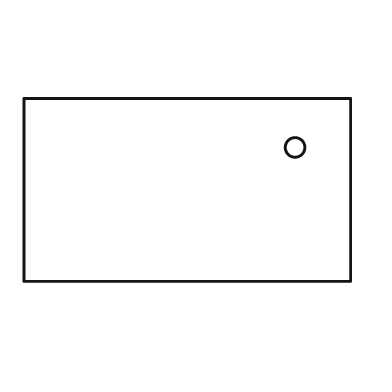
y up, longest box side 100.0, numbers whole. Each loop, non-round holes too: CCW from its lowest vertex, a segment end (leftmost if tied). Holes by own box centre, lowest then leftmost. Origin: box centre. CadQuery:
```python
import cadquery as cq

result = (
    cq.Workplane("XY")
    .moveTo(-50.0, -28.0)
    .lineTo(50.0, -28.0)
    .lineTo(50.0, 28.0)
    .lineTo(-50.0, 28.0)
    .close()
    .moveTo(33.0, 13.0)
    .circle(3.0)
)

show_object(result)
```